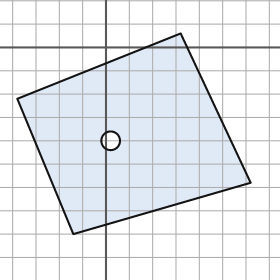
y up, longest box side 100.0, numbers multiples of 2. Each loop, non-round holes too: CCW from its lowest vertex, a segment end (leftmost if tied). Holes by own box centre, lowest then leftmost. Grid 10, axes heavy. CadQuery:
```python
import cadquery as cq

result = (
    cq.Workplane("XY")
    .moveTo(-14.0, -80.0)
    .lineTo(62.0, -58.0)
    .lineTo(32.0, 6.0)
    .lineTo(-38.0, -22.0)
    .close()
    .moveTo(2.0, -40.0)
    .circle(4.0)
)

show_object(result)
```